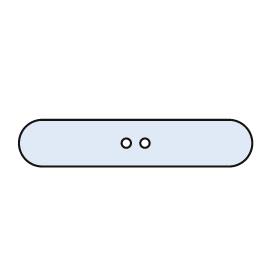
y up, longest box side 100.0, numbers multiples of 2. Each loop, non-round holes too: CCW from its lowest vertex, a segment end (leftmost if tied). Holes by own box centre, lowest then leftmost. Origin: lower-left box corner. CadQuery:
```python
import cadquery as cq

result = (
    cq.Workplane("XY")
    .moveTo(10.0, 0.0)
    .lineTo(90.0, 0.0)
    .threePointArc((100.0, 10.0), (90.0, 20.0))
    .lineTo(10.0, 20.0)
    .threePointArc((0.0, 10.0), (10.0, 0.0))
    .close()
    .moveTo(46.0, 10.0)
    .circle(2.0)
    .moveTo(54.0, 10.0)
    .circle(2.0)
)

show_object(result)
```